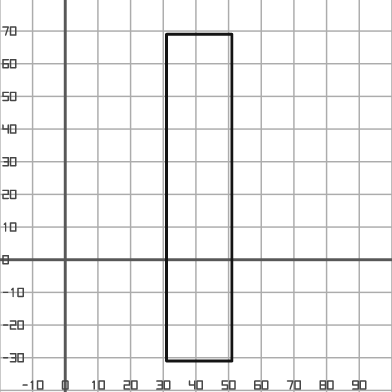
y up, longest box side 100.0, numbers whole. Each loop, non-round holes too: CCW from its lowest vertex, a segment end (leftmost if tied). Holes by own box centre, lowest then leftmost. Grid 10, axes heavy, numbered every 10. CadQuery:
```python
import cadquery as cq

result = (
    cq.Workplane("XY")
    .moveTo(31.0, -31.0)
    .lineTo(51.0, -31.0)
    .lineTo(51.0, 69.0)
    .lineTo(31.0, 69.0)
    .close()
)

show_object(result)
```